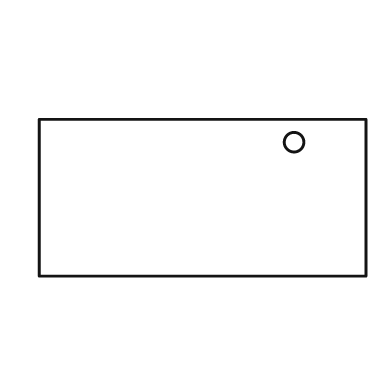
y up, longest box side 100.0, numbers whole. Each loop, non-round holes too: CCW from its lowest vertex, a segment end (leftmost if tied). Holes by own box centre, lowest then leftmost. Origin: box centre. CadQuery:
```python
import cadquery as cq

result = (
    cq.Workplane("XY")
    .moveTo(-50.0, -24.0)
    .lineTo(50.0, -24.0)
    .lineTo(50.0, 24.0)
    .lineTo(-50.0, 24.0)
    .close()
    .moveTo(28.0, 17.0)
    .circle(3.0)
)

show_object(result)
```